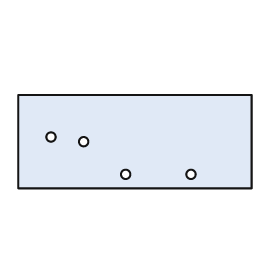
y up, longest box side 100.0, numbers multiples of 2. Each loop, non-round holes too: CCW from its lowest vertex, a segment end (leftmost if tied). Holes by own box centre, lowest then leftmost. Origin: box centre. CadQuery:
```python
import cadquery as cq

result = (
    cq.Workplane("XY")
    .moveTo(-50.0, -20.0)
    .lineTo(50.0, -20.0)
    .lineTo(50.0, 20.0)
    .lineTo(-50.0, 20.0)
    .close()
    .moveTo(-4.0, -14.0)
    .circle(2.0)
    .moveTo(24.0, -14.0)
    .circle(2.0)
    .moveTo(-22.0, 0.0)
    .circle(2.0)
    .moveTo(-36.0, 2.0)
    .circle(2.0)
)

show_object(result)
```